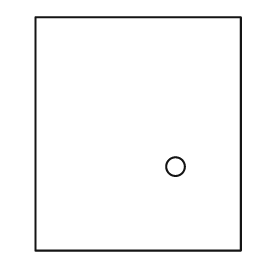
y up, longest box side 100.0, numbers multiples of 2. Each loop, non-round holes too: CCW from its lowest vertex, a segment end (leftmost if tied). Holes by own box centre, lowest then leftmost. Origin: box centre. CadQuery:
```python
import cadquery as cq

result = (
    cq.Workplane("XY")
    .moveTo(-44.0, -50.0)
    .lineTo(44.0, -50.0)
    .lineTo(44.0, 50.0)
    .lineTo(-44.0, 50.0)
    .close()
    .moveTo(16.0, -14.0)
    .circle(4.0)
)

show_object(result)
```